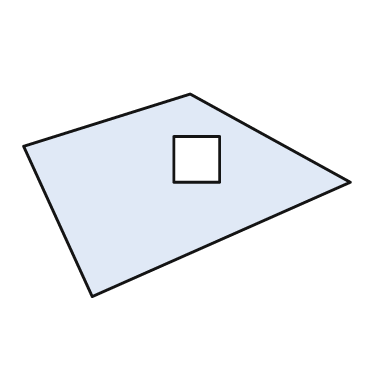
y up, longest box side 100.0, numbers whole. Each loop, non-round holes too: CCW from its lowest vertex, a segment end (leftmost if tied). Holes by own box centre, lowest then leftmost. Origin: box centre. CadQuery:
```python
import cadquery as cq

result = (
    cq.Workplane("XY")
    .moveTo(-29.0, -31.0)
    .lineTo(50.0, 4.0)
    .lineTo(1.0, 31.0)
    .lineTo(-50.0, 15.0)
    .close()
    .moveTo(-4.0, 4.0)
    .lineTo(10.0, 4.0)
    .lineTo(10.0, 18.0)
    .lineTo(-4.0, 18.0)
    .close()
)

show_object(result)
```